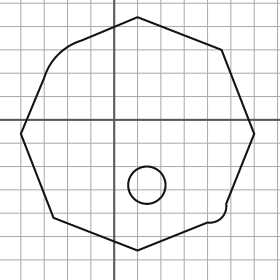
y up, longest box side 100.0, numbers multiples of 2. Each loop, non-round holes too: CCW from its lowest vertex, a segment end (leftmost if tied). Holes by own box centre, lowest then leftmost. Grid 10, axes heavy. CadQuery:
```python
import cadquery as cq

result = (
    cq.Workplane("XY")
    .moveTo(10.0, -56.0)
    .lineTo(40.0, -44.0)
    .threePointArc((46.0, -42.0), (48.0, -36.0))
    .lineTo(60.0, -6.0)
    .lineTo(46.0, 30.0)
    .lineTo(10.0, 44.0)
    .lineTo(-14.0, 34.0)
    .threePointArc((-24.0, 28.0), (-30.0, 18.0))
    .lineTo(-40.0, -6.0)
    .lineTo(-26.0, -42.0)
    .close()
    .moveTo(14.0, -28.0)
    .circle(8.0)
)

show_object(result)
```